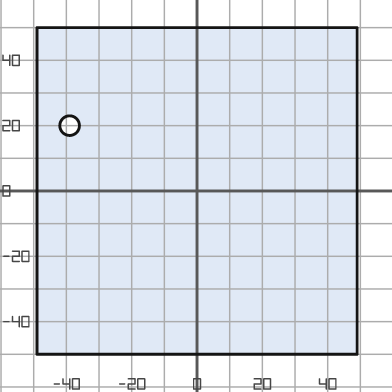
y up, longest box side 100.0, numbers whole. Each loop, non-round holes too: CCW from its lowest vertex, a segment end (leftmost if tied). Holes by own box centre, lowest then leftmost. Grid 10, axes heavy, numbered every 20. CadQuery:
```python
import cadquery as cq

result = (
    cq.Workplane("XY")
    .moveTo(-49.0, -50.0)
    .lineTo(49.0, -50.0)
    .lineTo(49.0, 50.0)
    .lineTo(-49.0, 50.0)
    .close()
    .moveTo(-39.0, 20.0)
    .circle(3.0)
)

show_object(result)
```